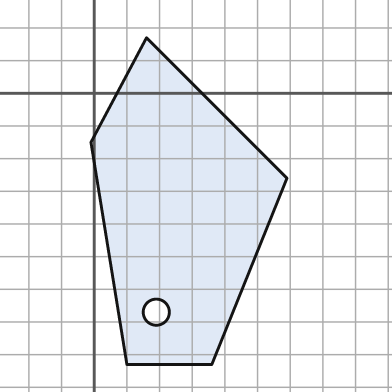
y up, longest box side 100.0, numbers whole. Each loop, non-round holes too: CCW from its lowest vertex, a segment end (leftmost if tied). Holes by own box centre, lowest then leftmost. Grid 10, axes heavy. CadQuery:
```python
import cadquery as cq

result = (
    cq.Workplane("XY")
    .moveTo(10.0, -83.0)
    .lineTo(36.0, -83.0)
    .lineTo(59.0, -26.0)
    .lineTo(16.0, 17.0)
    .lineTo(-1.0, -15.0)
    .close()
    .moveTo(19.0, -67.0)
    .circle(4.0)
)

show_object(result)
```